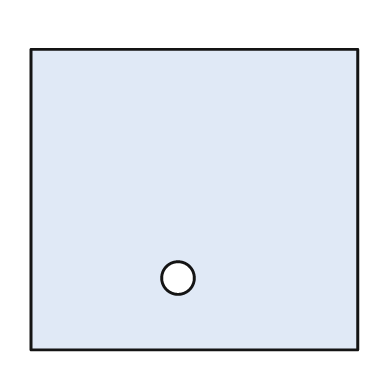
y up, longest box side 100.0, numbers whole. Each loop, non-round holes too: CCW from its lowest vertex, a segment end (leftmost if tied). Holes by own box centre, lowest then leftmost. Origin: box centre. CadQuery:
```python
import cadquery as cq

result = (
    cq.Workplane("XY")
    .moveTo(-50.0, -46.0)
    .lineTo(50.0, -46.0)
    .lineTo(50.0, 46.0)
    .lineTo(-50.0, 46.0)
    .close()
    .moveTo(-5.0, -24.0)
    .circle(5.0)
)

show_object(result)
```